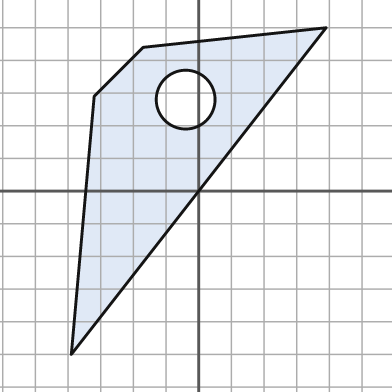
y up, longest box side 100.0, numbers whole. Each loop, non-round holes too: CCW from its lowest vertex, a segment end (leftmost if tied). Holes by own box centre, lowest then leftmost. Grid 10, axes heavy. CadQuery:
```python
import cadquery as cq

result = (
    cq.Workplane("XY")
    .moveTo(-39.0, -50.0)
    .lineTo(39.0, 50.0)
    .lineTo(-17.0, 44.0)
    .lineTo(-32.0, 29.0)
    .close()
    .moveTo(-4.0, 28.0)
    .circle(9.0)
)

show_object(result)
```